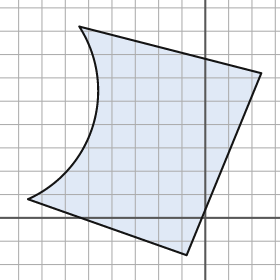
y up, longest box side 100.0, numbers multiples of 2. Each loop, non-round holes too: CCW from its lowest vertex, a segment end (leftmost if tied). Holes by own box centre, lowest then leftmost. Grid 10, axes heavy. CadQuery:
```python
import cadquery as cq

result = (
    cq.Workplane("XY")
    .moveTo(-8.0, -16.0)
    .lineTo(24.0, 62.0)
    .lineTo(-54.0, 82.0)
    .threePointArc((-48.0, 40.0), (-76.0, 8.0))
    .close()
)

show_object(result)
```